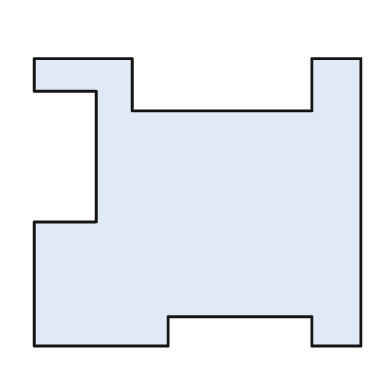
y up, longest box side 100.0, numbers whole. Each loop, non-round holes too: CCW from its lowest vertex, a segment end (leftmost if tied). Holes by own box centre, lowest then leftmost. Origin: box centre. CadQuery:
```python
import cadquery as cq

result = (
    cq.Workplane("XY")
    .moveTo(-50.0, -44.0)
    .lineTo(-9.0, -44.0)
    .lineTo(-9.0, -35.0)
    .lineTo(35.0, -35.0)
    .lineTo(35.0, -44.0)
    .lineTo(50.0, -44.0)
    .lineTo(50.0, 44.0)
    .lineTo(35.0, 44.0)
    .lineTo(35.0, 28.0)
    .lineTo(-20.0, 28.0)
    .lineTo(-20.0, 44.0)
    .lineTo(-50.0, 44.0)
    .lineTo(-50.0, 34.0)
    .lineTo(-31.0, 34.0)
    .lineTo(-31.0, -6.0)
    .lineTo(-50.0, -6.0)
    .close()
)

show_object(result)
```